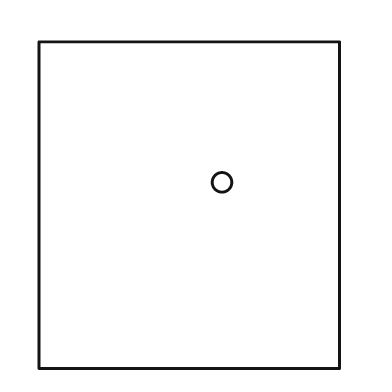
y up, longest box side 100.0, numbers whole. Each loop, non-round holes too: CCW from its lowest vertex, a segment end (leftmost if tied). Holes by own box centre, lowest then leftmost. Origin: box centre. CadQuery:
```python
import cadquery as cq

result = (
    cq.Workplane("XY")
    .moveTo(-46.0, -50.0)
    .lineTo(46.0, -50.0)
    .lineTo(46.0, 50.0)
    .lineTo(-46.0, 50.0)
    .close()
    .moveTo(10.0, 7.0)
    .circle(3.0)
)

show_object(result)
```